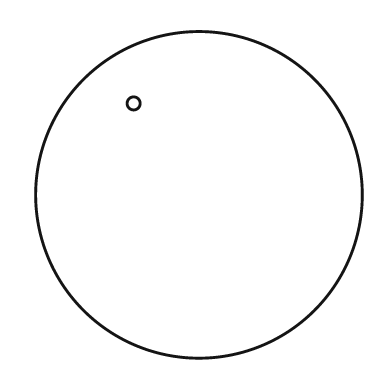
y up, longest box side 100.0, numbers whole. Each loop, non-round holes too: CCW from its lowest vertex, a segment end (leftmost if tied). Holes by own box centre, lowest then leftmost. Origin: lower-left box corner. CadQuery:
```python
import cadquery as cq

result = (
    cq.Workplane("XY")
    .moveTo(50.0, 50.0)
    .circle(50.0)
    .moveTo(30.0, 78.0)
    .circle(2.0)
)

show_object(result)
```